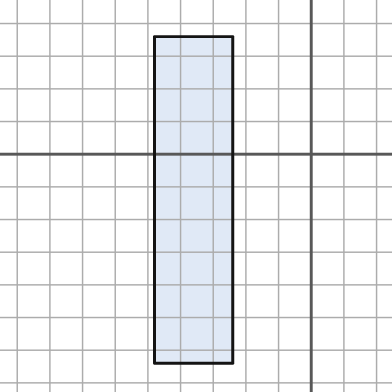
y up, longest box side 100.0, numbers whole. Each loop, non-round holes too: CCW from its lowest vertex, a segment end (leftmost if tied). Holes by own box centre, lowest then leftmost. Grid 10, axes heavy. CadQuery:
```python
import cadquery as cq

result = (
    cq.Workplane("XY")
    .moveTo(-48.0, -64.0)
    .lineTo(-24.0, -64.0)
    .lineTo(-24.0, 36.0)
    .lineTo(-48.0, 36.0)
    .close()
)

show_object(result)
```